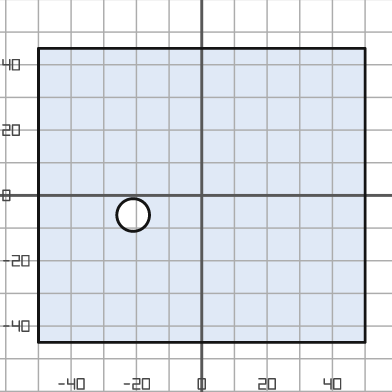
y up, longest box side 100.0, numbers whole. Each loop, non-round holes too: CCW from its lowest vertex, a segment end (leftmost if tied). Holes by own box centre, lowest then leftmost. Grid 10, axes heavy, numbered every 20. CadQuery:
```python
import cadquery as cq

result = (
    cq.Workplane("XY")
    .moveTo(-50.0, -45.0)
    .lineTo(50.0, -45.0)
    .lineTo(50.0, 45.0)
    .lineTo(-50.0, 45.0)
    .close()
    .moveTo(-21.0, -6.0)
    .circle(5.0)
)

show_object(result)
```